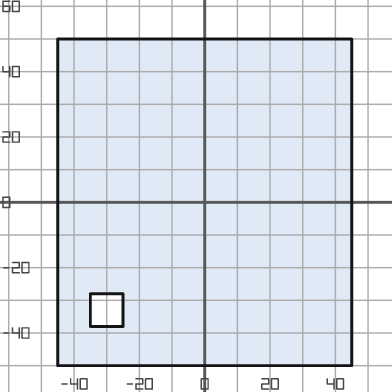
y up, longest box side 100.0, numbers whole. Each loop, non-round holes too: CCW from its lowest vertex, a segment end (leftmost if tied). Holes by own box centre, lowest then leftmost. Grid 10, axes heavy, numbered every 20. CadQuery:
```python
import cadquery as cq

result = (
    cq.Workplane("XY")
    .moveTo(-45.0, -50.0)
    .lineTo(45.0, -50.0)
    .lineTo(45.0, 50.0)
    .lineTo(-45.0, 50.0)
    .close()
    .moveTo(-35.0, -38.0)
    .lineTo(-25.0, -38.0)
    .lineTo(-25.0, -28.0)
    .lineTo(-35.0, -28.0)
    .close()
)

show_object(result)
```